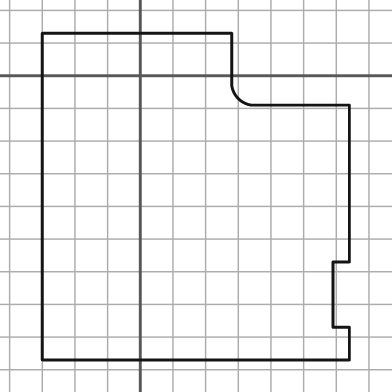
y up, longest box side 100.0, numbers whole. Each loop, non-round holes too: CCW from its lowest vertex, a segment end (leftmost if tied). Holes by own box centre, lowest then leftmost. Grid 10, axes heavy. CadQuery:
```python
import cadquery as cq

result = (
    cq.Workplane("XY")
    .moveTo(-30.0, -87.0)
    .lineTo(64.0, -87.0)
    .lineTo(64.0, -77.0)
    .lineTo(59.0, -77.0)
    .lineTo(59.0, -57.0)
    .lineTo(64.0, -57.0)
    .lineTo(64.0, -9.0)
    .lineTo(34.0, -9.0)
    .threePointArc((30.0, -7.0), (28.0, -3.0))
    .lineTo(28.0, 13.0)
    .lineTo(-30.0, 13.0)
    .close()
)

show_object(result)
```